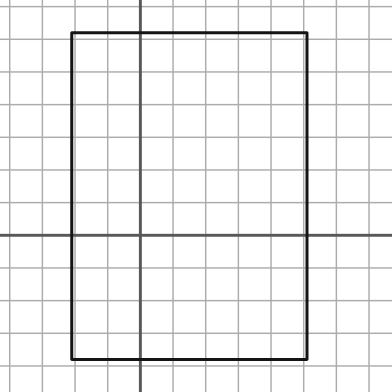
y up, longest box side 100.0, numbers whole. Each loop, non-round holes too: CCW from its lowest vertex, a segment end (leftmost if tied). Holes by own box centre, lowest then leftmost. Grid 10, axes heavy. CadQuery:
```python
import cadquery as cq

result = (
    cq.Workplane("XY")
    .moveTo(-21.0, -38.0)
    .lineTo(51.0, -38.0)
    .lineTo(51.0, 62.0)
    .lineTo(-21.0, 62.0)
    .close()
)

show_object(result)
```